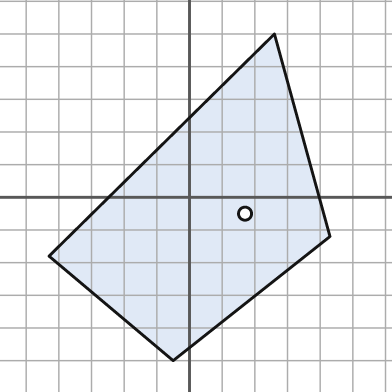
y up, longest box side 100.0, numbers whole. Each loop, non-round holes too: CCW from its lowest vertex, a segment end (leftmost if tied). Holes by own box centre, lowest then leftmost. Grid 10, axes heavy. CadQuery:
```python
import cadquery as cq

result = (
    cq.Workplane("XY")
    .moveTo(-5.0, -50.0)
    .lineTo(43.0, -12.0)
    .lineTo(26.0, 50.0)
    .lineTo(-43.0, -18.0)
    .close()
    .moveTo(17.0, -5.0)
    .circle(2.0)
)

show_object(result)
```